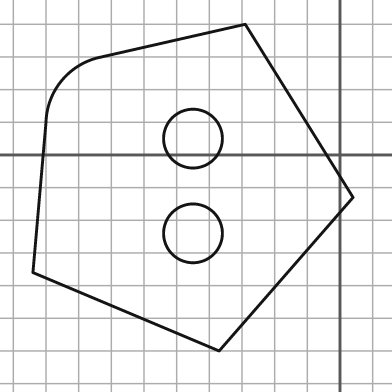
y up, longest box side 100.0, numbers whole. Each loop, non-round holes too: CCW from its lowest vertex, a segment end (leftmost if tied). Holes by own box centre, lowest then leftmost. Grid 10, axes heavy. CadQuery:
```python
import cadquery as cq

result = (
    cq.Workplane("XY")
    .moveTo(-37.0, -60.0)
    .lineTo(4.0, -13.0)
    .lineTo(-29.0, 40.0)
    .lineTo(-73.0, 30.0)
    .threePointArc((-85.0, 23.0), (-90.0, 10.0))
    .lineTo(-94.0, -36.0)
    .close()
    .moveTo(-45.0, -24.0)
    .circle(9.0)
    .moveTo(-45.0, 5.0)
    .circle(9.0)
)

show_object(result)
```